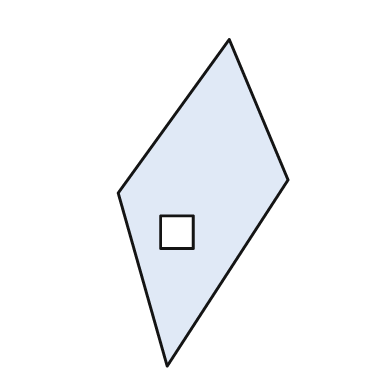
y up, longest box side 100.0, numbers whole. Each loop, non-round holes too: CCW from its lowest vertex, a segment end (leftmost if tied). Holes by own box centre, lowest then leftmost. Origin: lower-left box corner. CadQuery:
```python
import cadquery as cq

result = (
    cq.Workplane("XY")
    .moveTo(15.0, 0.0)
    .lineTo(52.0, 57.0)
    .lineTo(34.0, 100.0)
    .lineTo(0.0, 53.0)
    .close()
    .moveTo(13.0, 36.0)
    .lineTo(23.0, 36.0)
    .lineTo(23.0, 46.0)
    .lineTo(13.0, 46.0)
    .close()
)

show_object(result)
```